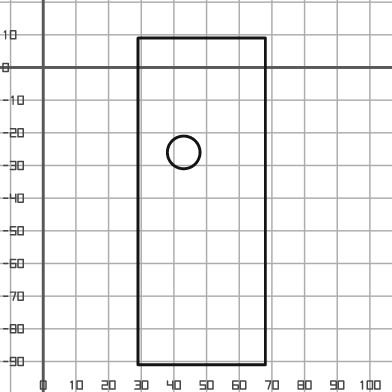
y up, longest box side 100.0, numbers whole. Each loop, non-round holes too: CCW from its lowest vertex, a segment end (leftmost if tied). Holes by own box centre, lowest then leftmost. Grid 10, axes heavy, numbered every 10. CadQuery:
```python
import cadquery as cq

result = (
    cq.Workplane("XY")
    .moveTo(29.0, -91.0)
    .lineTo(68.0, -91.0)
    .lineTo(68.0, 9.0)
    .lineTo(29.0, 9.0)
    .close()
    .moveTo(43.0, -26.0)
    .circle(5.0)
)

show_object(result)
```